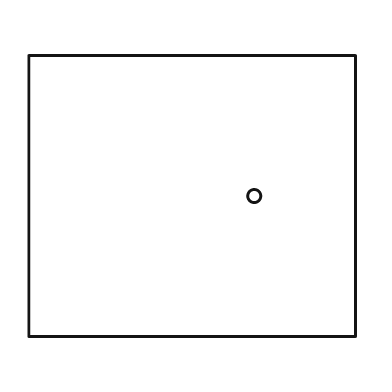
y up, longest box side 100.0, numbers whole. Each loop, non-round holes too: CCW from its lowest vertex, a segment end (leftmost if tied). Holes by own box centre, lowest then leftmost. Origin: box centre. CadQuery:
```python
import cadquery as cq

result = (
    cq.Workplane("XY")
    .moveTo(-50.0, -43.0)
    .lineTo(50.0, -43.0)
    .lineTo(50.0, 43.0)
    .lineTo(-50.0, 43.0)
    .close()
    .moveTo(19.0, 0.0)
    .circle(2.0)
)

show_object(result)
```